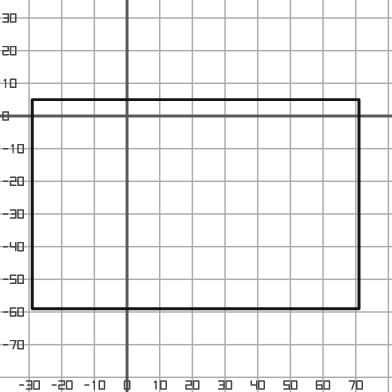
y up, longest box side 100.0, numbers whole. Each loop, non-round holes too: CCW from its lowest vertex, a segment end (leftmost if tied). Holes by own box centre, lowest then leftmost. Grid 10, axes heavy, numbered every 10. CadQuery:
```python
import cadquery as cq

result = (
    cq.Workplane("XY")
    .moveTo(-29.0, -59.0)
    .lineTo(71.0, -59.0)
    .lineTo(71.0, 5.0)
    .lineTo(-29.0, 5.0)
    .close()
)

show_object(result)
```